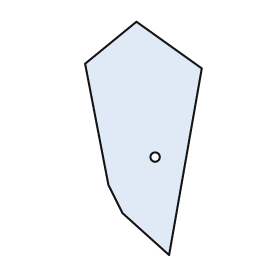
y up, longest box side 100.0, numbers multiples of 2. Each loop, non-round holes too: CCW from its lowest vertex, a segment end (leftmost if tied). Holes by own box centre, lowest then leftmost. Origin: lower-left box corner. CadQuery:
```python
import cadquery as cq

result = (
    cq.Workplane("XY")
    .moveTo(36.0, 0.0)
    .lineTo(50.0, 80.0)
    .lineTo(22.0, 100.0)
    .lineTo(0.0, 82.0)
    .lineTo(10.0, 30.0)
    .lineTo(16.0, 18.0)
    .close()
    .moveTo(30.0, 42.0)
    .circle(2.0)
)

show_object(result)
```